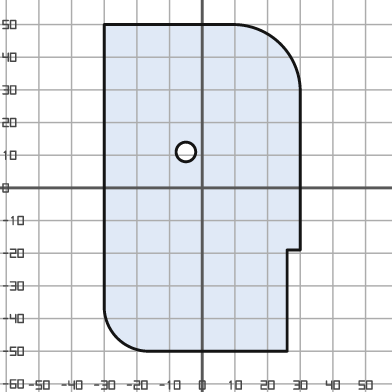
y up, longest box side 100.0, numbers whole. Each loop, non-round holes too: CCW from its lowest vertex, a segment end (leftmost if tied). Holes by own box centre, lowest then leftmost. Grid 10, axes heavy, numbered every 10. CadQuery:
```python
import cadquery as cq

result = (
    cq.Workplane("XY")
    .moveTo(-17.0, -50.0)
    .lineTo(26.0, -50.0)
    .lineTo(26.0, -19.0)
    .lineTo(30.0, -19.0)
    .lineTo(30.0, 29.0)
    .threePointArc((24.0, 44.0), (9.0, 50.0))
    .lineTo(-30.0, 50.0)
    .lineTo(-30.0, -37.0)
    .threePointArc((-26.0, -46.0), (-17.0, -50.0))
    .close()
    .moveTo(-5.0, 11.0)
    .circle(3.0)
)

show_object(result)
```